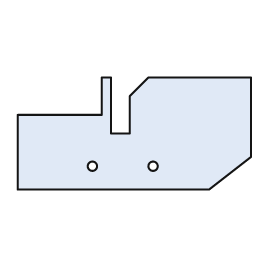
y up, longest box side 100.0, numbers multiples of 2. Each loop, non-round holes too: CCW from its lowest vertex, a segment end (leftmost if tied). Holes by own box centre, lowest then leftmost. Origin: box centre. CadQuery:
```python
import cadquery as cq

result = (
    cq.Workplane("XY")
    .moveTo(-50.0, -24.0)
    .lineTo(32.0, -24.0)
    .lineTo(50.0, -10.0)
    .lineTo(50.0, 24.0)
    .lineTo(6.0, 24.0)
    .lineTo(-2.0, 16.0)
    .lineTo(-2.0, 0.0)
    .lineTo(-10.0, 0.0)
    .lineTo(-10.0, 24.0)
    .lineTo(-14.0, 24.0)
    .lineTo(-14.0, 8.0)
    .lineTo(-50.0, 8.0)
    .close()
    .moveTo(-18.0, -14.0)
    .circle(2.0)
    .moveTo(8.0, -14.0)
    .circle(2.0)
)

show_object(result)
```